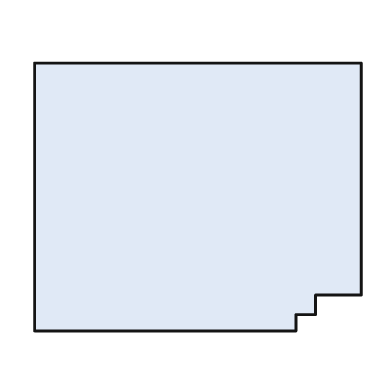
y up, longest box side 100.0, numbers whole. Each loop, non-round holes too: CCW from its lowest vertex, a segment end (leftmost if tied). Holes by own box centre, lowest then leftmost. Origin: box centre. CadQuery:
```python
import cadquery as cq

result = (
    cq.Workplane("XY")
    .moveTo(-50.0, -41.0)
    .lineTo(30.0, -41.0)
    .lineTo(30.0, -36.0)
    .lineTo(36.0, -36.0)
    .lineTo(36.0, -30.0)
    .lineTo(50.0, -30.0)
    .lineTo(50.0, 41.0)
    .lineTo(-50.0, 41.0)
    .close()
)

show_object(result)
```